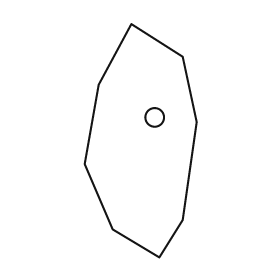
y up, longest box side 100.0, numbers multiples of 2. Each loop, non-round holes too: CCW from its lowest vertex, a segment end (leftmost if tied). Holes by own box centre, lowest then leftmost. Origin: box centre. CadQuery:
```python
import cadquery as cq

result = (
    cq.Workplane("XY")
    .moveTo(8.0, -50.0)
    .lineTo(18.0, -34.0)
    .lineTo(24.0, 8.0)
    .lineTo(18.0, 36.0)
    .lineTo(-4.0, 50.0)
    .lineTo(-18.0, 24.0)
    .lineTo(-24.0, -10.0)
    .lineTo(-12.0, -38.0)
    .close()
    .moveTo(6.0, 10.0)
    .circle(4.0)
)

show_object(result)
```